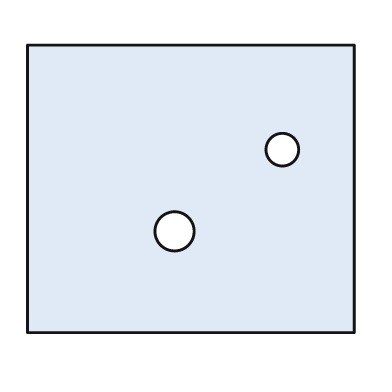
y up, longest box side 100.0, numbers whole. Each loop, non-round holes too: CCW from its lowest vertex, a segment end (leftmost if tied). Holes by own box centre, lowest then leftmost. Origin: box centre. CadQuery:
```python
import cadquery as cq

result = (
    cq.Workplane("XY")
    .moveTo(-50.0, -44.0)
    .lineTo(50.0, -44.0)
    .lineTo(50.0, 44.0)
    .lineTo(-50.0, 44.0)
    .close()
    .moveTo(-5.0, -13.0)
    .circle(6.0)
    .moveTo(28.0, 12.0)
    .circle(5.0)
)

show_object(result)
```